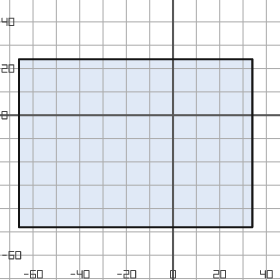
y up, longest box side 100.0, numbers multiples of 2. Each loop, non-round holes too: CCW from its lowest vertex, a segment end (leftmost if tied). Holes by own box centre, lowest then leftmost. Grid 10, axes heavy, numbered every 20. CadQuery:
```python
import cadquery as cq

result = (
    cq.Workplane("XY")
    .moveTo(-66.0, -48.0)
    .lineTo(34.0, -48.0)
    .lineTo(34.0, 24.0)
    .lineTo(-66.0, 24.0)
    .close()
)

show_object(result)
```